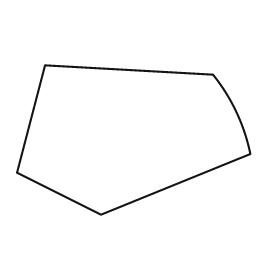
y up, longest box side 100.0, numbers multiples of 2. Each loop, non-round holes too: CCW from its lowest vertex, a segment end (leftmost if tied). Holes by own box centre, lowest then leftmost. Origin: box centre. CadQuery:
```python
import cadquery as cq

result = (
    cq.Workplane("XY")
    .moveTo(-14.0, -32.0)
    .lineTo(50.0, -6.0)
    .threePointArc((44.0, 12.0), (34.0, 28.0))
    .lineTo(-38.0, 32.0)
    .lineTo(-50.0, -14.0)
    .close()
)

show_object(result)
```